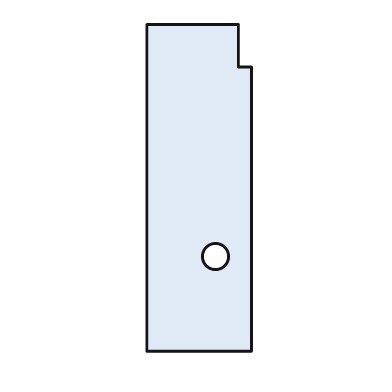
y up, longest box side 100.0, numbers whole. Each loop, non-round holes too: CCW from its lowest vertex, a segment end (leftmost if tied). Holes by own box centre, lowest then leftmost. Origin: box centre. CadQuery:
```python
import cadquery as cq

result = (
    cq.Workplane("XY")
    .moveTo(-16.0, -50.0)
    .lineTo(16.0, -50.0)
    .lineTo(16.0, 37.0)
    .lineTo(12.0, 37.0)
    .lineTo(12.0, 50.0)
    .lineTo(-16.0, 50.0)
    .close()
    .moveTo(5.0, -21.0)
    .circle(4.0)
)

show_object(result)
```